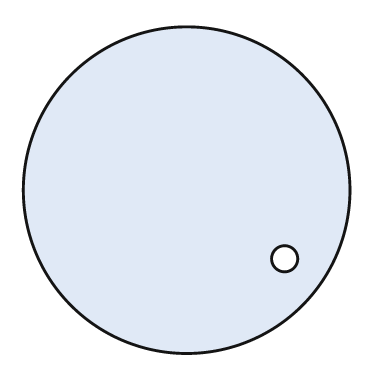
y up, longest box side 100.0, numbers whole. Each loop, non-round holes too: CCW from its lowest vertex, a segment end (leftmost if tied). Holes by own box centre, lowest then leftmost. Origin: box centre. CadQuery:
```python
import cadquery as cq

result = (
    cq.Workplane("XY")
    .moveTo(0.0, 0.0)
    .circle(50.0)
    .moveTo(30.0, -21.0)
    .circle(4.0)
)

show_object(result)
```